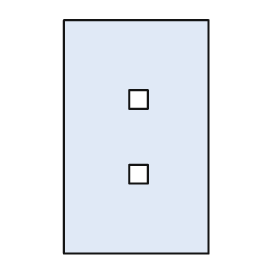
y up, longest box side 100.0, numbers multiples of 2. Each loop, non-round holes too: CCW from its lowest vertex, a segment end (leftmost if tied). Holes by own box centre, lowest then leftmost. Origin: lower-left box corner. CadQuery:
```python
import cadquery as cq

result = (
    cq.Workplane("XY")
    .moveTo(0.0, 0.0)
    .lineTo(62.0, 0.0)
    .lineTo(62.0, 100.0)
    .lineTo(0.0, 100.0)
    .close()
    .moveTo(28.0, 30.0)
    .lineTo(36.0, 30.0)
    .lineTo(36.0, 38.0)
    .lineTo(28.0, 38.0)
    .close()
    .moveTo(28.0, 62.0)
    .lineTo(36.0, 62.0)
    .lineTo(36.0, 70.0)
    .lineTo(28.0, 70.0)
    .close()
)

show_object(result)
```